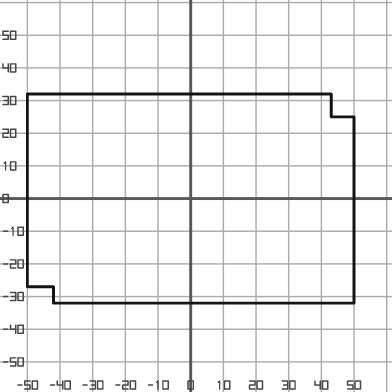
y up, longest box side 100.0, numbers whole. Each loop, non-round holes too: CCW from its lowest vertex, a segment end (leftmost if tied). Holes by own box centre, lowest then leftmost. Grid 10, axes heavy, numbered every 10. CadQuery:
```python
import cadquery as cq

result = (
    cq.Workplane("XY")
    .moveTo(-42.0, -32.0)
    .lineTo(50.0, -32.0)
    .lineTo(50.0, 25.0)
    .lineTo(43.0, 25.0)
    .lineTo(43.0, 32.0)
    .lineTo(-50.0, 32.0)
    .lineTo(-50.0, -27.0)
    .lineTo(-42.0, -27.0)
    .close()
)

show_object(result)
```